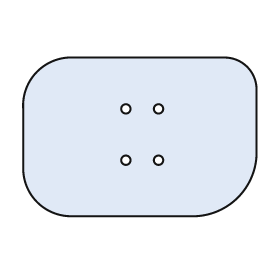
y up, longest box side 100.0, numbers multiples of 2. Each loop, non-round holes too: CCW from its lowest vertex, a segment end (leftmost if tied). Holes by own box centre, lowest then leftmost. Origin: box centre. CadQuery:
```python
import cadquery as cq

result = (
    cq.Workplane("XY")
    .moveTo(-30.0, -34.0)
    .lineTo(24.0, -34.0)
    .threePointArc((42.0, -26.0), (50.0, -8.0))
    .lineTo(50.0, 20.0)
    .threePointArc((46.0, 30.0), (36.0, 34.0))
    .lineTo(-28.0, 34.0)
    .threePointArc((-44.0, 28.0), (-50.0, 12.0))
    .lineTo(-50.0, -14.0)
    .threePointArc((-44.0, -28.0), (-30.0, -34.0))
    .close()
    .moveTo(-6.0, -10.0)
    .circle(2.0)
    .moveTo(8.0, -10.0)
    .circle(2.0)
    .moveTo(-6.0, 12.0)
    .circle(2.0)
    .moveTo(8.0, 12.0)
    .circle(2.0)
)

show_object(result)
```